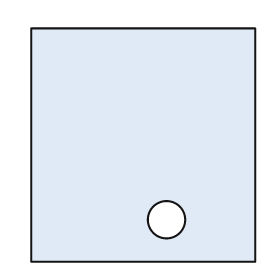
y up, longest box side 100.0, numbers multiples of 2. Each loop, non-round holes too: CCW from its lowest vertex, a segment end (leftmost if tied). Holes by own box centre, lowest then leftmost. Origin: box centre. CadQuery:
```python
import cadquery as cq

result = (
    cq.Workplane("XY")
    .moveTo(-48.0, -50.0)
    .lineTo(48.0, -50.0)
    .lineTo(48.0, 50.0)
    .lineTo(-48.0, 50.0)
    .close()
    .moveTo(10.0, -32.0)
    .circle(8.0)
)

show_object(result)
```